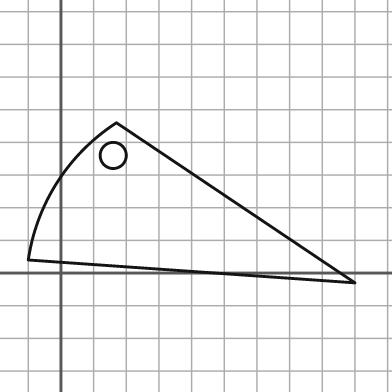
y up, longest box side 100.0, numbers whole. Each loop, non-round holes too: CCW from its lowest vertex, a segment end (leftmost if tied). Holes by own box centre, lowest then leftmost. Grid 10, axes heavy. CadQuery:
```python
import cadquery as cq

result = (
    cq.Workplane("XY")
    .moveTo(90.0, -3.0)
    .lineTo(17.0, 46.0)
    .threePointArc((-1.0, 28.0), (-10.0, 4.0))
    .close()
    .moveTo(16.0, 36.0)
    .circle(4.0)
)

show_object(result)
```